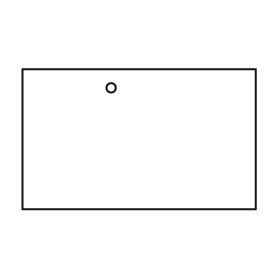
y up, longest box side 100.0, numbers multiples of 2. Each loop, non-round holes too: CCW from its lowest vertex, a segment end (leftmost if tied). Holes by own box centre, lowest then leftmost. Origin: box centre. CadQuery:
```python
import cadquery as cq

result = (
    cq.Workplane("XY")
    .moveTo(-50.0, -30.0)
    .lineTo(50.0, -30.0)
    .lineTo(50.0, 30.0)
    .lineTo(-50.0, 30.0)
    .close()
    .moveTo(-12.0, 22.0)
    .circle(2.0)
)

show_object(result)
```